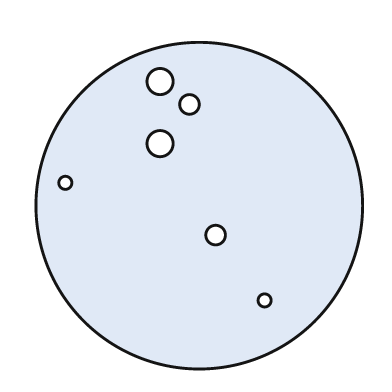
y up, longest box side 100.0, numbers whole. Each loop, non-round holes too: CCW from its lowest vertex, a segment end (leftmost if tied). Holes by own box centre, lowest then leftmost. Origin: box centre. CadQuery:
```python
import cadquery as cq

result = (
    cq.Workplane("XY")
    .moveTo(0.0, 0.0)
    .circle(50.0)
    .moveTo(20.0, -29.0)
    .circle(2.0)
    .moveTo(5.0, -9.0)
    .circle(3.0)
    .moveTo(-41.0, 7.0)
    .circle(2.0)
    .moveTo(-12.0, 19.0)
    .circle(4.0)
    .moveTo(-3.0, 31.0)
    .circle(3.0)
    .moveTo(-12.0, 38.0)
    .circle(4.0)
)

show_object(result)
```